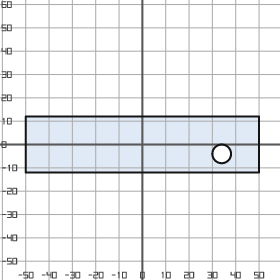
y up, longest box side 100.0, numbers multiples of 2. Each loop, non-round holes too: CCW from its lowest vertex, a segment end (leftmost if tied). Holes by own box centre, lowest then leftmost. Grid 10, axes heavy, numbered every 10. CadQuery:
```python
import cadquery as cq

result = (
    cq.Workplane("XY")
    .moveTo(-50.0, -12.0)
    .lineTo(50.0, -12.0)
    .lineTo(50.0, 12.0)
    .lineTo(-50.0, 12.0)
    .close()
    .moveTo(34.0, -4.0)
    .circle(4.0)
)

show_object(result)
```